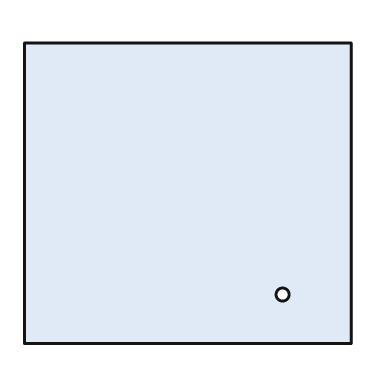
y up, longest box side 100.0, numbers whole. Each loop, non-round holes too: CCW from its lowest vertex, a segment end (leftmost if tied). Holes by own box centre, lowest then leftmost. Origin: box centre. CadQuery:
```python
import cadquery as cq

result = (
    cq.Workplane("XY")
    .moveTo(-50.0, -46.0)
    .lineTo(50.0, -46.0)
    .lineTo(50.0, 46.0)
    .lineTo(-50.0, 46.0)
    .close()
    .moveTo(29.0, -31.0)
    .circle(2.0)
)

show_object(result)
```